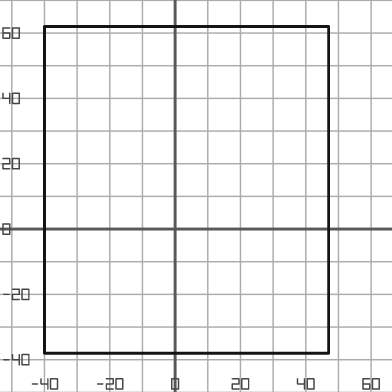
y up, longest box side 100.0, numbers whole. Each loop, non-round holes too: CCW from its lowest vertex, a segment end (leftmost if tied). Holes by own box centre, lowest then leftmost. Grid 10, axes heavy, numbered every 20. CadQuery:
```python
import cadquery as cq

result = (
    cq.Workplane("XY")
    .moveTo(-40.0, -38.0)
    .lineTo(47.0, -38.0)
    .lineTo(47.0, 62.0)
    .lineTo(-40.0, 62.0)
    .close()
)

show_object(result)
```